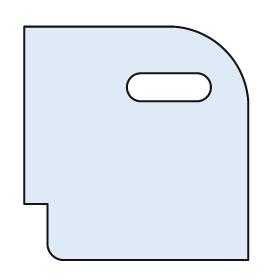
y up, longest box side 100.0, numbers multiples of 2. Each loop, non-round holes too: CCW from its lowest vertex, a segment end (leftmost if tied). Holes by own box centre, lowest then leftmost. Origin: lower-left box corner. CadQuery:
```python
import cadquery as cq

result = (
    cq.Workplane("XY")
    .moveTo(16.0, 0.0)
    .lineTo(96.0, 0.0)
    .lineTo(96.0, 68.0)
    .threePointArc((86.0, 90.0), (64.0, 100.0))
    .lineTo(0.0, 100.0)
    .lineTo(0.0, 24.0)
    .lineTo(10.0, 24.0)
    .lineTo(10.0, 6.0)
    .threePointArc((12.0, 2.0), (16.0, 0.0))
    .close()
    .moveTo(50.0, 68.0)
    .lineTo(74.0, 68.0)
    .threePointArc((80.0, 74.0), (74.0, 80.0))
    .lineTo(50.0, 80.0)
    .threePointArc((44.0, 74.0), (50.0, 68.0))
    .close()
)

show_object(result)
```